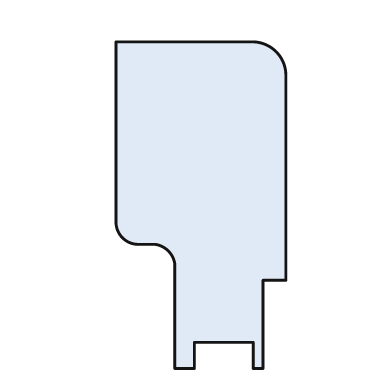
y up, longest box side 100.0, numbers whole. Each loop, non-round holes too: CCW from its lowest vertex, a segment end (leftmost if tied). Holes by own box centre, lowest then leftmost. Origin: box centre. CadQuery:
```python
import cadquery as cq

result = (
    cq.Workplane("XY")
    .moveTo(-8.0, -50.0)
    .lineTo(-2.0, -50.0)
    .lineTo(-2.0, -42.0)
    .lineTo(16.0, -42.0)
    .lineTo(16.0, -50.0)
    .lineTo(19.0, -50.0)
    .lineTo(19.0, -23.0)
    .lineTo(26.0, -23.0)
    .lineTo(26.0, 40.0)
    .threePointArc((23.0, 47.0), (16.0, 50.0))
    .lineTo(-26.0, 50.0)
    .lineTo(-26.0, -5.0)
    .threePointArc((-24.0, -10.0), (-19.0, -12.0))
    .lineTo(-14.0, -12.0)
    .threePointArc((-10.0, -14.0), (-8.0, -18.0))
    .close()
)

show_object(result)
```